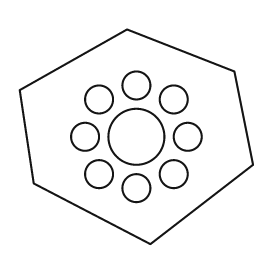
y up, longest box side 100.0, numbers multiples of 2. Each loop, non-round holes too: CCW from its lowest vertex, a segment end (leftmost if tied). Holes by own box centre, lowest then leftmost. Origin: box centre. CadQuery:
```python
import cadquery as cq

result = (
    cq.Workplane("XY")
    .moveTo(6.0, -46.0)
    .lineTo(50.0, -12.0)
    .lineTo(42.0, 28.0)
    .lineTo(-4.0, 46.0)
    .lineTo(-50.0, 20.0)
    .lineTo(-44.0, -20.0)
    .close()
    .moveTo(0.0, -22.0)
    .circle(6.0)
    .moveTo(-16.0, -16.0)
    .circle(6.0)
    .moveTo(16.0, -16.0)
    .circle(6.0)
    .moveTo(-22.0, 0.0)
    .circle(6.0)
    .moveTo(0.0, 0.0)
    .circle(12.0)
    .moveTo(22.0, 0.0)
    .circle(6.0)
    .moveTo(-16.0, 16.0)
    .circle(6.0)
    .moveTo(16.0, 16.0)
    .circle(6.0)
    .moveTo(0.0, 22.0)
    .circle(6.0)
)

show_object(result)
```